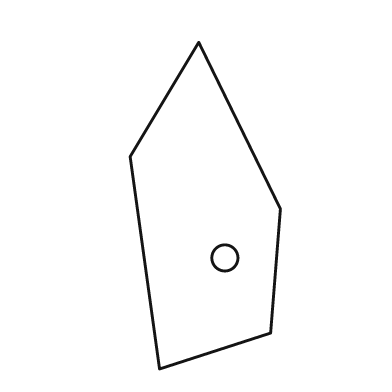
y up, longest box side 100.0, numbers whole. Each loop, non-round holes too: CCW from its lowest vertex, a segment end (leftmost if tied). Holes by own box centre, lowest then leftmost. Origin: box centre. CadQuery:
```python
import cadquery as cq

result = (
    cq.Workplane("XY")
    .moveTo(-14.0, -50.0)
    .lineTo(20.0, -39.0)
    .lineTo(23.0, -1.0)
    .lineTo(-2.0, 50.0)
    .lineTo(-23.0, 15.0)
    .close()
    .moveTo(6.0, -16.0)
    .circle(4.0)
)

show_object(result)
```